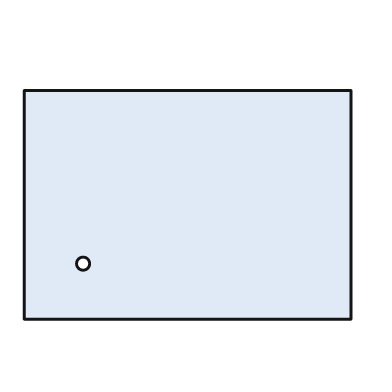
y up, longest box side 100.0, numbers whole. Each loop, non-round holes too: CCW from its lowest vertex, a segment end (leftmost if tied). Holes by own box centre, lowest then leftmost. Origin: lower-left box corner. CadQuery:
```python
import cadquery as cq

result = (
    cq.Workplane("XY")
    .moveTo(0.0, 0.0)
    .lineTo(100.0, 0.0)
    .lineTo(100.0, 70.0)
    .lineTo(0.0, 70.0)
    .close()
    .moveTo(18.0, 17.0)
    .circle(2.0)
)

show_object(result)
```